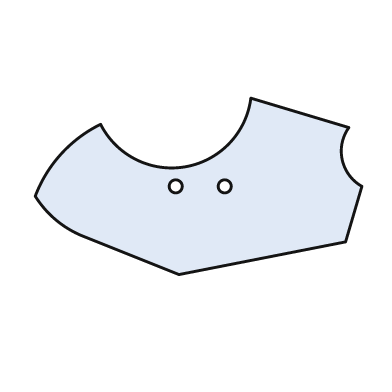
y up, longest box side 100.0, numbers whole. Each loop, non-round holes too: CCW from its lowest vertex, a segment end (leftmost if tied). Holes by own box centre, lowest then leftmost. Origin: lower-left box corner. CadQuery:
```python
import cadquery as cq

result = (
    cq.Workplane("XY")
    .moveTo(44.0, 0.0)
    .lineTo(95.0, 10.0)
    .lineTo(100.0, 27.0)
    .threePointArc((94.0, 35.0), (96.0, 45.0))
    .lineTo(66.0, 54.0)
    .threePointArc((46.0, 33.0), (20.0, 46.0))
    .threePointArc((8.0, 37.0), (0.0, 24.0))
    .threePointArc((6.0, 17.0), (14.0, 12.0))
    .close()
    .moveTo(43.0, 27.0)
    .circle(2.0)
    .moveTo(58.0, 27.0)
    .circle(2.0)
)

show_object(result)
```